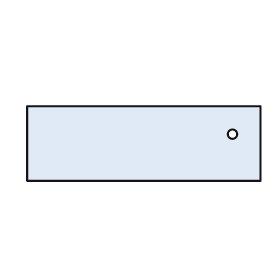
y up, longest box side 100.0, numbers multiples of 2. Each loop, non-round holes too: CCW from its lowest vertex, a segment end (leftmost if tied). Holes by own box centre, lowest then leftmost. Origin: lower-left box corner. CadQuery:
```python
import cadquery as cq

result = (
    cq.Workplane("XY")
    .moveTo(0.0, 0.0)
    .lineTo(100.0, 0.0)
    .lineTo(100.0, 32.0)
    .lineTo(0.0, 32.0)
    .close()
    .moveTo(88.0, 20.0)
    .circle(2.0)
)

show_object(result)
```